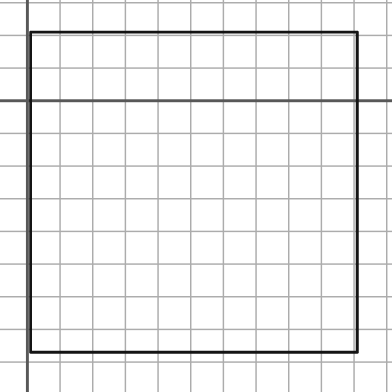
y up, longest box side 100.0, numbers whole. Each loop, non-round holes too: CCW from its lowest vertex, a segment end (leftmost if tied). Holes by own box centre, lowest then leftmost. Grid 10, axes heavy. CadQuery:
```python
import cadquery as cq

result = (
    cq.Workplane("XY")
    .moveTo(1.0, -77.0)
    .lineTo(101.0, -77.0)
    .lineTo(101.0, 21.0)
    .lineTo(1.0, 21.0)
    .close()
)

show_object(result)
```